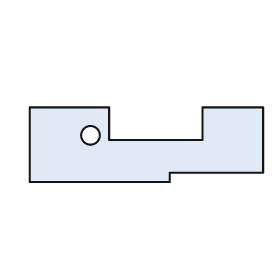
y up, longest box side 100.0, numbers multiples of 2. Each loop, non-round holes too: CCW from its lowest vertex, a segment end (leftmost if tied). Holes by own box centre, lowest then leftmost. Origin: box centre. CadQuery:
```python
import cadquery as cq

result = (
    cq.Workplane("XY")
    .moveTo(-50.0, -16.0)
    .lineTo(10.0, -16.0)
    .lineTo(10.0, -12.0)
    .lineTo(50.0, -12.0)
    .lineTo(50.0, 16.0)
    .lineTo(24.0, 16.0)
    .lineTo(24.0, 2.0)
    .lineTo(-16.0, 2.0)
    .lineTo(-16.0, 16.0)
    .lineTo(-50.0, 16.0)
    .close()
    .moveTo(-24.0, 4.0)
    .circle(4.0)
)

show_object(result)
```